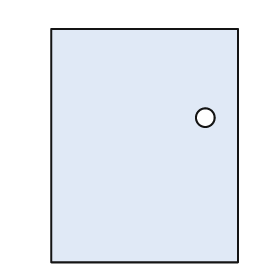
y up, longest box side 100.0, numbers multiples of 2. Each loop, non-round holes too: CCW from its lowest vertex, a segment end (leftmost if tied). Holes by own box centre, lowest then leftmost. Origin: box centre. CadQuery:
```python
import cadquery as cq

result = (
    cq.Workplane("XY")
    .moveTo(-40.0, -50.0)
    .lineTo(40.0, -50.0)
    .lineTo(40.0, 50.0)
    .lineTo(-40.0, 50.0)
    .close()
    .moveTo(26.0, 12.0)
    .circle(4.0)
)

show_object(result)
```